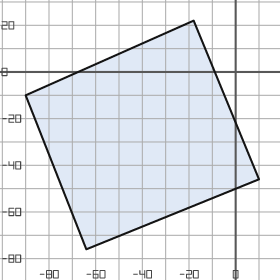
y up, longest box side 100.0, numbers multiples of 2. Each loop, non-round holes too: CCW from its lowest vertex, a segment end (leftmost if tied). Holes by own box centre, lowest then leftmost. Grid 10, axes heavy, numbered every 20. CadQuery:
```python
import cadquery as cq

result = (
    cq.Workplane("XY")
    .moveTo(-64.0, -76.0)
    .lineTo(10.0, -46.0)
    .lineTo(-18.0, 22.0)
    .lineTo(-90.0, -10.0)
    .close()
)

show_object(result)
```